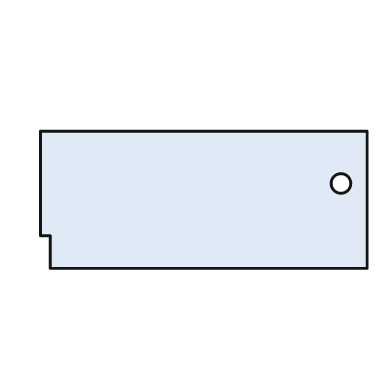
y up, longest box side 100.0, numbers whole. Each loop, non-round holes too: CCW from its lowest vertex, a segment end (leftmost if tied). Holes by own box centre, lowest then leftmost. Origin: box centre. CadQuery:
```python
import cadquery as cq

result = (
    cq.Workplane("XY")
    .moveTo(-47.0, -21.0)
    .lineTo(50.0, -21.0)
    .lineTo(50.0, 21.0)
    .lineTo(-50.0, 21.0)
    .lineTo(-50.0, -11.0)
    .lineTo(-47.0, -11.0)
    .close()
    .moveTo(42.0, 5.0)
    .circle(3.0)
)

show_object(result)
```